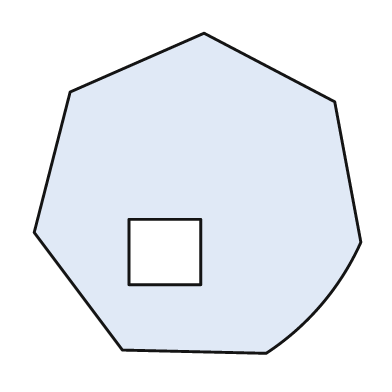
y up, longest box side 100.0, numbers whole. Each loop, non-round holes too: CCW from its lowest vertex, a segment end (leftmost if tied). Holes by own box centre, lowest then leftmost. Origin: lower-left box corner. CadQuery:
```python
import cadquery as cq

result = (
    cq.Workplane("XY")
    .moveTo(71.0, 0.0)
    .threePointArc((88.0, 15.0), (100.0, 34.0))
    .lineTo(92.0, 77.0)
    .lineTo(52.0, 98.0)
    .lineTo(11.0, 80.0)
    .lineTo(0.0, 37.0)
    .lineTo(27.0, 1.0)
    .close()
    .moveTo(29.0, 21.0)
    .lineTo(51.0, 21.0)
    .lineTo(51.0, 41.0)
    .lineTo(29.0, 41.0)
    .close()
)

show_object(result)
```